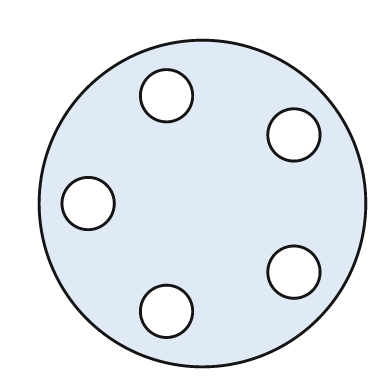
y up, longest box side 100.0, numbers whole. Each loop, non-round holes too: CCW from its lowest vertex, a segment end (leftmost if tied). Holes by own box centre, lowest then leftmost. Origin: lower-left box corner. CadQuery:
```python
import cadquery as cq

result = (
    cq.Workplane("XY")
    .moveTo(50.0, 50.0)
    .circle(50.0)
    .moveTo(39.0, 17.0)
    .circle(8.0)
    .moveTo(78.0, 29.0)
    .circle(8.0)
    .moveTo(15.0, 50.0)
    .circle(8.0)
    .moveTo(78.0, 71.0)
    .circle(8.0)
    .moveTo(39.0, 83.0)
    .circle(8.0)
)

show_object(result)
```